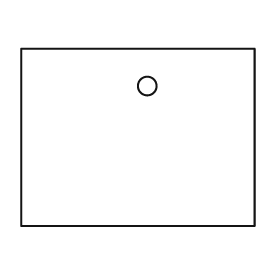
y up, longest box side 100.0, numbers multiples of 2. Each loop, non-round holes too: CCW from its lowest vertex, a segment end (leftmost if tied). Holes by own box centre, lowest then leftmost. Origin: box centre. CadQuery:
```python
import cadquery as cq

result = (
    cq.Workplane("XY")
    .moveTo(-50.0, -38.0)
    .lineTo(50.0, -38.0)
    .lineTo(50.0, 38.0)
    .lineTo(-50.0, 38.0)
    .close()
    .moveTo(4.0, 22.0)
    .circle(4.0)
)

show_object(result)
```